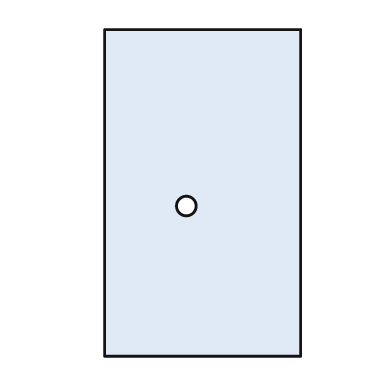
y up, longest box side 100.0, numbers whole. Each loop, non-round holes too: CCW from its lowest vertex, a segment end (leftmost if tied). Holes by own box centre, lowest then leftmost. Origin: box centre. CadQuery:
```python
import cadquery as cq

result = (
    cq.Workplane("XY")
    .moveTo(-30.0, -50.0)
    .lineTo(30.0, -50.0)
    .lineTo(30.0, 50.0)
    .lineTo(-30.0, 50.0)
    .close()
    .moveTo(-5.0, -4.0)
    .circle(3.0)
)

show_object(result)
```